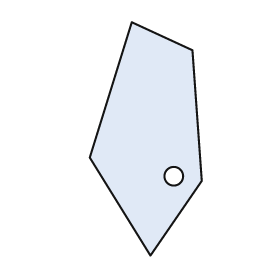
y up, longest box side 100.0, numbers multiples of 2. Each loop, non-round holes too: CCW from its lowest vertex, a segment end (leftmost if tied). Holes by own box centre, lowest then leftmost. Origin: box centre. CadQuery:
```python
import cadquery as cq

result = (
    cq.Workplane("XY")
    .moveTo(2.0, -50.0)
    .lineTo(24.0, -18.0)
    .lineTo(20.0, 38.0)
    .lineTo(-6.0, 50.0)
    .lineTo(-24.0, -8.0)
    .close()
    .moveTo(12.0, -16.0)
    .circle(4.0)
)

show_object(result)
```